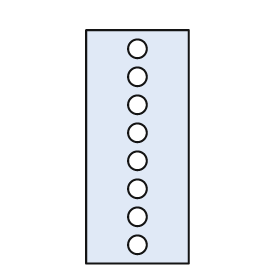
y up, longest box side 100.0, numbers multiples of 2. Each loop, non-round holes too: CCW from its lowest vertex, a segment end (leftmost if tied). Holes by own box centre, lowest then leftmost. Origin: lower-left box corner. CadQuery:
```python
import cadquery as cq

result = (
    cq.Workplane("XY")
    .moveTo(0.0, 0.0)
    .lineTo(44.0, 0.0)
    .lineTo(44.0, 100.0)
    .lineTo(0.0, 100.0)
    .close()
    .moveTo(22.0, 8.0)
    .circle(4.0)
    .moveTo(22.0, 20.0)
    .circle(4.0)
    .moveTo(22.0, 32.0)
    .circle(4.0)
    .moveTo(22.0, 44.0)
    .circle(4.0)
    .moveTo(22.0, 56.0)
    .circle(4.0)
    .moveTo(22.0, 68.0)
    .circle(4.0)
    .moveTo(22.0, 80.0)
    .circle(4.0)
    .moveTo(22.0, 92.0)
    .circle(4.0)
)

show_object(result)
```